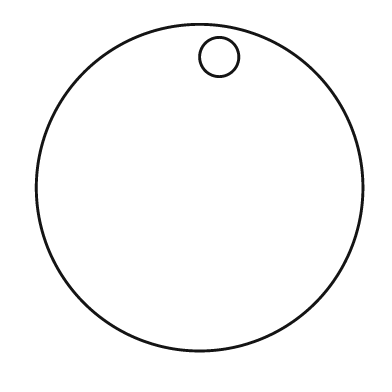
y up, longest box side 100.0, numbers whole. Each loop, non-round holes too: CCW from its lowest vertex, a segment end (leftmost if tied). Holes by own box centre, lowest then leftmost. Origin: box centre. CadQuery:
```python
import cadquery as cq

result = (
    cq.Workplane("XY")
    .moveTo(0.0, 0.0)
    .circle(50.0)
    .moveTo(6.0, 40.0)
    .circle(6.0)
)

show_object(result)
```